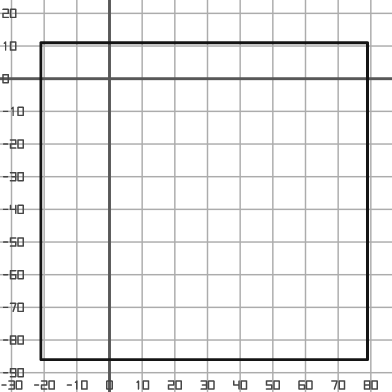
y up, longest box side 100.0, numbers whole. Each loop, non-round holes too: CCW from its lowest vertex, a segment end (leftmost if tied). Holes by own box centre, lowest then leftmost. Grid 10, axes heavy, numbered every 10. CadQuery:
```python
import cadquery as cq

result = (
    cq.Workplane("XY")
    .moveTo(-21.0, -86.0)
    .lineTo(79.0, -86.0)
    .lineTo(79.0, 11.0)
    .lineTo(-21.0, 11.0)
    .close()
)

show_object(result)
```